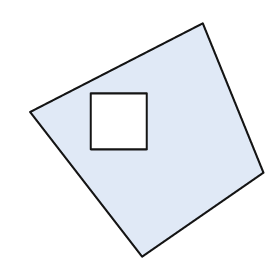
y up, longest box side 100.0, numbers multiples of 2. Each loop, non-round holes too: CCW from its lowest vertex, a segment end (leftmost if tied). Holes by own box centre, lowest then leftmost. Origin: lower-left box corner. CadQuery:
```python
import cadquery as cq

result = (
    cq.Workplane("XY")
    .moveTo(48.0, 0.0)
    .lineTo(100.0, 36.0)
    .lineTo(74.0, 100.0)
    .lineTo(0.0, 62.0)
    .close()
    .moveTo(26.0, 46.0)
    .lineTo(50.0, 46.0)
    .lineTo(50.0, 70.0)
    .lineTo(26.0, 70.0)
    .close()
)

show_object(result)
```